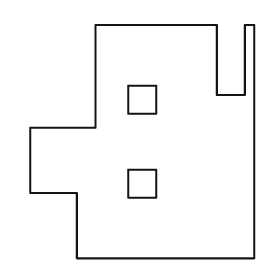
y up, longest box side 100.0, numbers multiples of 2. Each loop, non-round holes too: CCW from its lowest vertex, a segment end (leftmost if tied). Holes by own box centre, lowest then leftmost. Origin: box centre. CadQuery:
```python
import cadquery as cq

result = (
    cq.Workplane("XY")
    .moveTo(-28.0, -50.0)
    .lineTo(48.0, -50.0)
    .lineTo(48.0, 50.0)
    .lineTo(44.0, 50.0)
    .lineTo(44.0, 20.0)
    .lineTo(32.0, 20.0)
    .lineTo(32.0, 50.0)
    .lineTo(-20.0, 50.0)
    .lineTo(-20.0, 6.0)
    .lineTo(-48.0, 6.0)
    .lineTo(-48.0, -22.0)
    .lineTo(-28.0, -22.0)
    .close()
    .moveTo(-6.0, -24.0)
    .lineTo(6.0, -24.0)
    .lineTo(6.0, -12.0)
    .lineTo(-6.0, -12.0)
    .close()
    .moveTo(-6.0, 12.0)
    .lineTo(6.0, 12.0)
    .lineTo(6.0, 24.0)
    .lineTo(-6.0, 24.0)
    .close()
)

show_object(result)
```